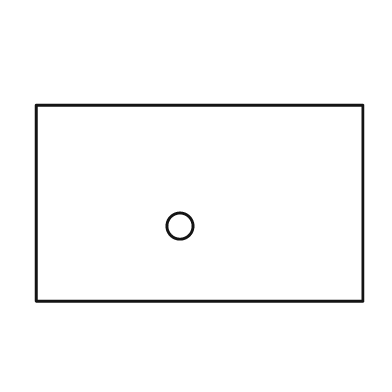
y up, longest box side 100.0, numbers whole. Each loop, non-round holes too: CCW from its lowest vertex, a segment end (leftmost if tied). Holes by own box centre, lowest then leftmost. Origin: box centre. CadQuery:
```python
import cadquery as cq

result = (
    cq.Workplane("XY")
    .moveTo(-50.0, -30.0)
    .lineTo(50.0, -30.0)
    .lineTo(50.0, 30.0)
    .lineTo(-50.0, 30.0)
    .close()
    .moveTo(-6.0, -7.0)
    .circle(4.0)
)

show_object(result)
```